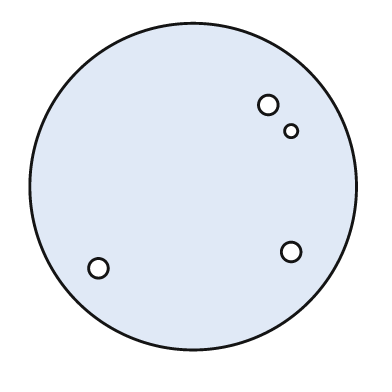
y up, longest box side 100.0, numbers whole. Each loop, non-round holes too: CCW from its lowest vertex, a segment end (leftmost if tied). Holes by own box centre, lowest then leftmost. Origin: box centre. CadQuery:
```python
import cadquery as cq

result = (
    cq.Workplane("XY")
    .moveTo(0.0, 0.0)
    .circle(50.0)
    .moveTo(-29.0, -25.0)
    .circle(3.0)
    .moveTo(30.0, -20.0)
    .circle(3.0)
    .moveTo(30.0, 17.0)
    .circle(2.0)
    .moveTo(23.0, 25.0)
    .circle(3.0)
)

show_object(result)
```